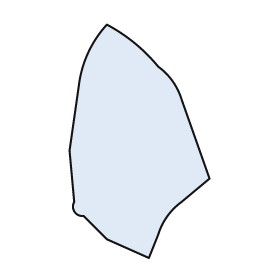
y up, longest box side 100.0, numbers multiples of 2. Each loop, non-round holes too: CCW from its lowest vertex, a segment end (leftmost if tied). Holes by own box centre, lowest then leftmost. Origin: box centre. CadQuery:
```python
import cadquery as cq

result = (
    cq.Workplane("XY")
    .moveTo(4.0, -50.0)
    .lineTo(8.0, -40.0)
    .threePointArc((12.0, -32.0), (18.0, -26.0))
    .lineTo(30.0, -16.0)
    .lineTo(18.0, 18.0)
    .threePointArc((14.0, 26.0), (8.0, 32.0))
    .threePointArc((-2.0, 42.0), (-14.0, 50.0))
    .threePointArc((-22.0, 38.0), (-26.0, 24.0))
    .lineTo(-30.0, -4.0)
    .lineTo(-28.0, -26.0)
    .threePointArc((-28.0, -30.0), (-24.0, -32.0))
    .lineTo(-14.0, -42.0)
    .close()
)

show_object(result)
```